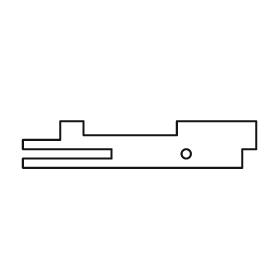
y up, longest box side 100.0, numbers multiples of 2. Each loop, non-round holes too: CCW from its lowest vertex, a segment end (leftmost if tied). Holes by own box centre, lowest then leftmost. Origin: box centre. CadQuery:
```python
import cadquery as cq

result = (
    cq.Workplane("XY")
    .moveTo(-50.0, -10.0)
    .lineTo(44.0, -10.0)
    .lineTo(44.0, -2.0)
    .lineTo(50.0, -2.0)
    .lineTo(50.0, 10.0)
    .lineTo(16.0, 10.0)
    .lineTo(16.0, 4.0)
    .lineTo(-24.0, 4.0)
    .lineTo(-24.0, 10.0)
    .lineTo(-34.0, 10.0)
    .lineTo(-34.0, 2.0)
    .lineTo(-50.0, 2.0)
    .lineTo(-50.0, -2.0)
    .lineTo(-12.0, -2.0)
    .lineTo(-12.0, -6.0)
    .lineTo(-50.0, -6.0)
    .close()
    .moveTo(20.0, -4.0)
    .circle(2.0)
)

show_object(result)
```